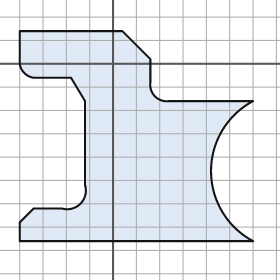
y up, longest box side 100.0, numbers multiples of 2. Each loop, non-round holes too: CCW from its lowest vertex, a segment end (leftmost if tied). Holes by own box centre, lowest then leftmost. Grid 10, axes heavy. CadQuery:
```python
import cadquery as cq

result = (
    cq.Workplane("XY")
    .moveTo(-40.0, -76.0)
    .lineTo(60.0, -76.0)
    .threePointArc((42.0, -46.0), (60.0, -16.0))
    .lineTo(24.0, -16.0)
    .threePointArc((18.0, -14.0), (16.0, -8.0))
    .lineTo(16.0, 2.0)
    .lineTo(4.0, 14.0)
    .lineTo(-40.0, 14.0)
    .lineTo(-40.0, 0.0)
    .threePointArc((-38.0, -4.0), (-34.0, -6.0))
    .lineTo(-18.0, -6.0)
    .lineTo(-12.0, -16.0)
    .lineTo(-12.0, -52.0)
    .threePointArc((-14.0, -60.0), (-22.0, -62.0))
    .lineTo(-34.0, -62.0)
    .lineTo(-40.0, -68.0)
    .close()
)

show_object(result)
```